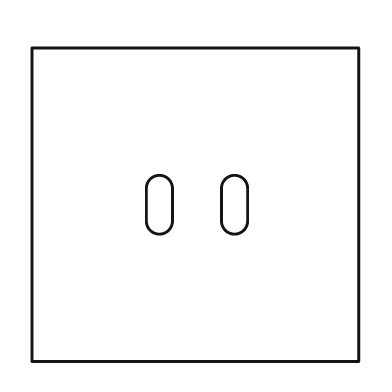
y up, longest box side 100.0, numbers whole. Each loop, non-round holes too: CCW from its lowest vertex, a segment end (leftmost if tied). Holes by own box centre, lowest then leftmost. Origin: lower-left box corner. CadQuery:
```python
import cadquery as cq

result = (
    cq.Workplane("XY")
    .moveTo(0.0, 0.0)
    .lineTo(100.0, 0.0)
    .lineTo(100.0, 96.0)
    .lineTo(0.0, 96.0)
    .close()
    .moveTo(35.0, 43.0)
    .threePointArc((39.0, 39.0), (43.0, 43.0))
    .lineTo(43.0, 53.0)
    .threePointArc((39.0, 57.0), (35.0, 53.0))
    .close()
    .moveTo(58.0, 43.0)
    .threePointArc((62.0, 39.0), (66.0, 43.0))
    .lineTo(66.0, 53.0)
    .threePointArc((62.0, 57.0), (58.0, 53.0))
    .close()
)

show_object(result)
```